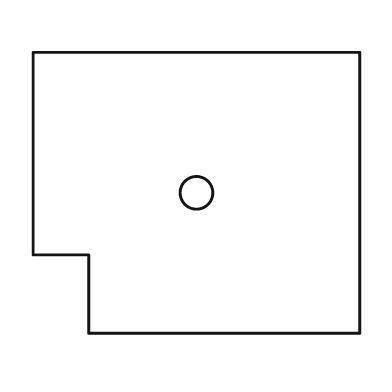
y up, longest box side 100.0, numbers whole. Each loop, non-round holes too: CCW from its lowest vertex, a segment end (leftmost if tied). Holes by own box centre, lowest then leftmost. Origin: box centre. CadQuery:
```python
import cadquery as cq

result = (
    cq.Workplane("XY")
    .moveTo(-33.0, -43.0)
    .lineTo(50.0, -43.0)
    .lineTo(50.0, 43.0)
    .lineTo(-50.0, 43.0)
    .lineTo(-50.0, -19.0)
    .lineTo(-33.0, -19.0)
    .close()
    .moveTo(0.0, 0.0)
    .circle(5.0)
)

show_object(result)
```